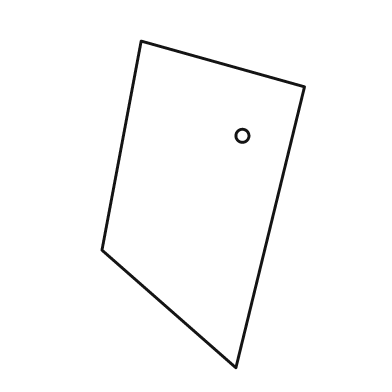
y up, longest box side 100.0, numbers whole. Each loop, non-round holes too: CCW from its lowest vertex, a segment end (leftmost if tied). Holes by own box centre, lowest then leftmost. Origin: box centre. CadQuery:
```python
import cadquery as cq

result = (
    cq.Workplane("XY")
    .moveTo(10.0, -50.0)
    .lineTo(31.0, 36.0)
    .lineTo(-19.0, 50.0)
    .lineTo(-31.0, -14.0)
    .close()
    .moveTo(12.0, 21.0)
    .circle(2.0)
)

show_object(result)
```